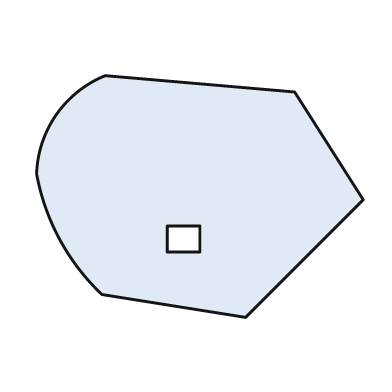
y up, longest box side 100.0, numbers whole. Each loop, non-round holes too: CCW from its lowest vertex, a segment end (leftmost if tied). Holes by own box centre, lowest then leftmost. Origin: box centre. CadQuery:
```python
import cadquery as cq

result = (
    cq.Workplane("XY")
    .moveTo(14.0, -37.0)
    .lineTo(50.0, -1.0)
    .lineTo(29.0, 32.0)
    .lineTo(-29.0, 37.0)
    .threePointArc((-44.0, 25.0), (-50.0, 7.0))
    .threePointArc((-43.0, -13.0), (-30.0, -30.0))
    .close()
    .moveTo(-10.0, -17.0)
    .lineTo(0.0, -17.0)
    .lineTo(0.0, -9.0)
    .lineTo(-10.0, -9.0)
    .close()
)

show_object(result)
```